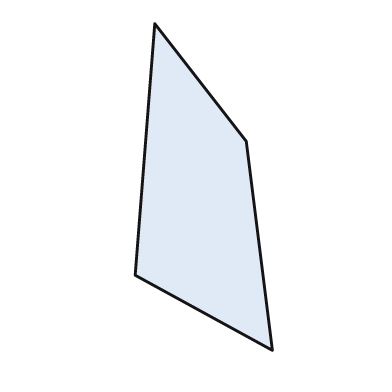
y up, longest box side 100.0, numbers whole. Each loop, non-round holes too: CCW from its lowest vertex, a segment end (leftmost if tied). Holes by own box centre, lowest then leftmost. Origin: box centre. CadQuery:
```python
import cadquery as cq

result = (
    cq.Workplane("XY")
    .moveTo(21.0, -50.0)
    .lineTo(13.0, 14.0)
    .lineTo(-15.0, 50.0)
    .lineTo(-21.0, -27.0)
    .close()
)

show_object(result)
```